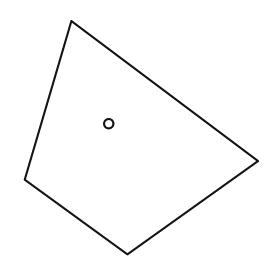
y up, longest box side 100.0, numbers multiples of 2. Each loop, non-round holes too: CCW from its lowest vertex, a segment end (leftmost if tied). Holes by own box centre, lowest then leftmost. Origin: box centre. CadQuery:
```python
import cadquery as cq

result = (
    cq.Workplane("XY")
    .moveTo(-6.0, -50.0)
    .lineTo(50.0, -10.0)
    .lineTo(-30.0, 50.0)
    .lineTo(-50.0, -18.0)
    .close()
    .moveTo(-14.0, 6.0)
    .circle(2.0)
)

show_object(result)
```